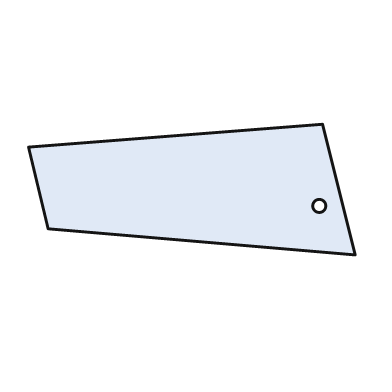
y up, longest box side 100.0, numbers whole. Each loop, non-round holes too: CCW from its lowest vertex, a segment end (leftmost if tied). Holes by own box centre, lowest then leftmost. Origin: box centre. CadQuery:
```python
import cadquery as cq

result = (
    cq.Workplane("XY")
    .moveTo(50.0, -20.0)
    .lineTo(40.0, 20.0)
    .lineTo(-50.0, 13.0)
    .lineTo(-44.0, -12.0)
    .close()
    .moveTo(39.0, -5.0)
    .circle(2.0)
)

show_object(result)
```